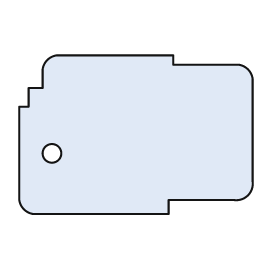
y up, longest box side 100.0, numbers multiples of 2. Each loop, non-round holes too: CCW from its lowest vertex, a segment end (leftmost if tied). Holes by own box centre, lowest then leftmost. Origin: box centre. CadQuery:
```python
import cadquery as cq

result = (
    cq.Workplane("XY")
    .moveTo(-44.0, -34.0)
    .lineTo(14.0, -34.0)
    .lineTo(14.0, -28.0)
    .lineTo(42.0, -28.0)
    .threePointArc((48.0, -26.0), (50.0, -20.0))
    .lineTo(50.0, 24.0)
    .threePointArc((48.0, 28.0), (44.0, 30.0))
    .lineTo(16.0, 30.0)
    .lineTo(16.0, 34.0)
    .lineTo(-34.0, 34.0)
    .threePointArc((-38.0, 32.0), (-40.0, 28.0))
    .lineTo(-40.0, 20.0)
    .lineTo(-46.0, 20.0)
    .lineTo(-46.0, 12.0)
    .lineTo(-50.0, 12.0)
    .lineTo(-50.0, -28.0)
    .threePointArc((-48.0, -32.0), (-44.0, -34.0))
    .close()
    .moveTo(-36.0, -8.0)
    .circle(4.0)
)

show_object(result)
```